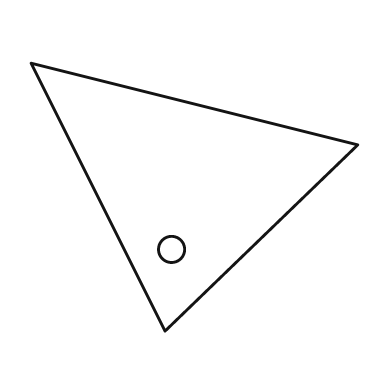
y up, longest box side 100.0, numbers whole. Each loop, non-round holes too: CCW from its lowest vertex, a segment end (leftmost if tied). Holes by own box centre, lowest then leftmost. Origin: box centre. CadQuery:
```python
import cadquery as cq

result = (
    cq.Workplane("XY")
    .moveTo(-9.0, -41.0)
    .lineTo(50.0, 16.0)
    .lineTo(-50.0, 41.0)
    .close()
    .moveTo(-7.0, -16.0)
    .circle(4.0)
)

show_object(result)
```